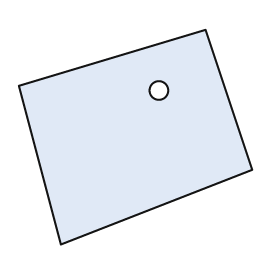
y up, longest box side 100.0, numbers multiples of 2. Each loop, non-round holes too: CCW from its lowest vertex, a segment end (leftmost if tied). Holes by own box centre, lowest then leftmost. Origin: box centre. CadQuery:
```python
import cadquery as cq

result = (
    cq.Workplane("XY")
    .moveTo(-32.0, -46.0)
    .lineTo(50.0, -14.0)
    .lineTo(30.0, 46.0)
    .lineTo(-50.0, 22.0)
    .close()
    .moveTo(10.0, 20.0)
    .circle(4.0)
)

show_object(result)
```